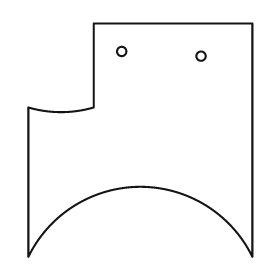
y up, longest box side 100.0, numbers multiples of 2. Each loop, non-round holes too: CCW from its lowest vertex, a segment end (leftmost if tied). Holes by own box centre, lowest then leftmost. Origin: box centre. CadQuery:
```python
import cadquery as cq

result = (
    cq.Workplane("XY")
    .moveTo(-48.0, -50.0)
    .threePointArc((0.0, -20.0), (48.0, -50.0))
    .lineTo(48.0, 50.0)
    .lineTo(-20.0, 50.0)
    .lineTo(-20.0, 14.0)
    .threePointArc((-34.0, 12.0), (-48.0, 14.0))
    .close()
    .moveTo(26.0, 36.0)
    .circle(2.0)
    .moveTo(-8.0, 38.0)
    .circle(2.0)
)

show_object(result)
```